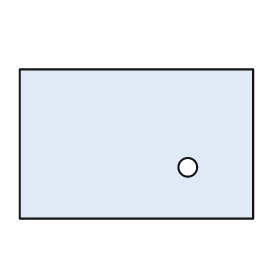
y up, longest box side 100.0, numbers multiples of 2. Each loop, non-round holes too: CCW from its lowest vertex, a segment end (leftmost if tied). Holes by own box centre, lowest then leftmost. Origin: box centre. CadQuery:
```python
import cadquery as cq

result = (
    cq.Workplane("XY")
    .moveTo(-50.0, -32.0)
    .lineTo(50.0, -32.0)
    .lineTo(50.0, 32.0)
    .lineTo(-50.0, 32.0)
    .close()
    .moveTo(22.0, -10.0)
    .circle(4.0)
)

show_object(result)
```